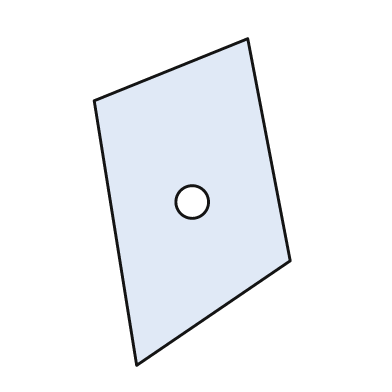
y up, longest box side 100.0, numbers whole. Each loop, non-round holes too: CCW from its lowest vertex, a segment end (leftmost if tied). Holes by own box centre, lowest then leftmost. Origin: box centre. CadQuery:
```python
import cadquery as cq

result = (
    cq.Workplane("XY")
    .moveTo(-17.0, -50.0)
    .lineTo(30.0, -18.0)
    .lineTo(17.0, 50.0)
    .lineTo(-30.0, 31.0)
    .close()
    .moveTo(0.0, 0.0)
    .circle(5.0)
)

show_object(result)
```